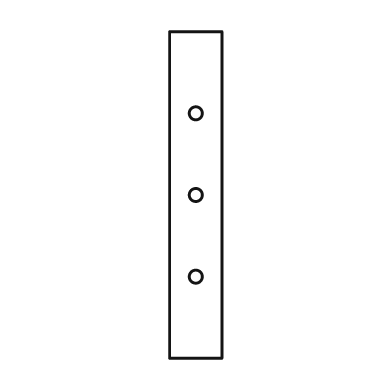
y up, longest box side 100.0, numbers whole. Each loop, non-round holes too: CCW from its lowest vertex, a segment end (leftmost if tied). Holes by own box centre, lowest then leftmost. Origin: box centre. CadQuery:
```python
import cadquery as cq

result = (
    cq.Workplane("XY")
    .moveTo(-8.0, -50.0)
    .lineTo(8.0, -50.0)
    .lineTo(8.0, 50.0)
    .lineTo(-8.0, 50.0)
    .close()
    .moveTo(0.0, -25.0)
    .circle(2.0)
    .moveTo(0.0, 0.0)
    .circle(2.0)
    .moveTo(0.0, 25.0)
    .circle(2.0)
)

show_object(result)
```